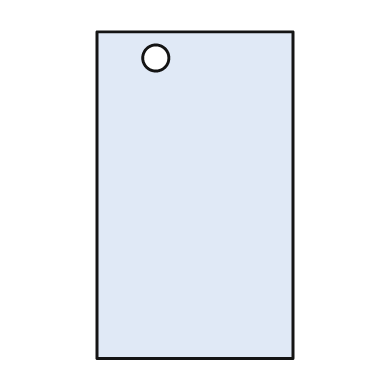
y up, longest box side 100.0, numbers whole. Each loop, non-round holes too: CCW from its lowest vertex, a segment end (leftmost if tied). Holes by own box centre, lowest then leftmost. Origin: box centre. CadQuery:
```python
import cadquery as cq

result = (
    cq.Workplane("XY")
    .moveTo(-30.0, -50.0)
    .lineTo(30.0, -50.0)
    .lineTo(30.0, 50.0)
    .lineTo(-30.0, 50.0)
    .close()
    .moveTo(-12.0, 42.0)
    .circle(4.0)
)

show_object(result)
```